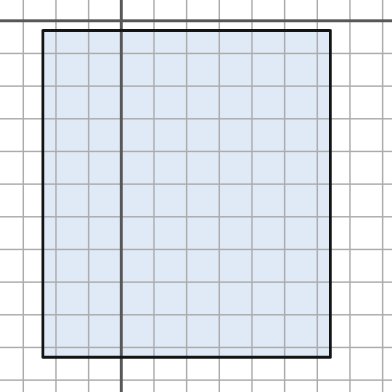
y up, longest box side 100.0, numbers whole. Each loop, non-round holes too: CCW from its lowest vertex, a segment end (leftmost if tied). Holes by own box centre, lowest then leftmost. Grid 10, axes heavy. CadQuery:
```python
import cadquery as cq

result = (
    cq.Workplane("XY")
    .moveTo(-24.0, -103.0)
    .lineTo(64.0, -103.0)
    .lineTo(64.0, -3.0)
    .lineTo(-24.0, -3.0)
    .close()
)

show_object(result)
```